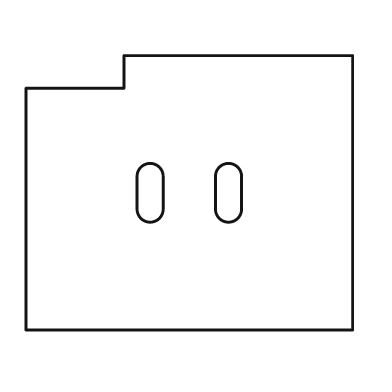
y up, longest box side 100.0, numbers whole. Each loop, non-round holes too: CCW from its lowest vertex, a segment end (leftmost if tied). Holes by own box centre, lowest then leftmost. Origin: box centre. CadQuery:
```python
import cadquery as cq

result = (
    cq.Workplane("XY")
    .moveTo(-50.0, -42.0)
    .lineTo(50.0, -42.0)
    .lineTo(50.0, 42.0)
    .lineTo(-20.0, 42.0)
    .lineTo(-20.0, 32.0)
    .lineTo(-50.0, 32.0)
    .close()
    .moveTo(-16.0, -5.0)
    .threePointArc((-12.0, -9.0), (-8.0, -5.0))
    .lineTo(-8.0, 5.0)
    .threePointArc((-12.0, 9.0), (-16.0, 5.0))
    .close()
    .moveTo(8.0, -5.0)
    .threePointArc((12.0, -9.0), (16.0, -5.0))
    .lineTo(16.0, 5.0)
    .threePointArc((12.0, 9.0), (8.0, 5.0))
    .close()
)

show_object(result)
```